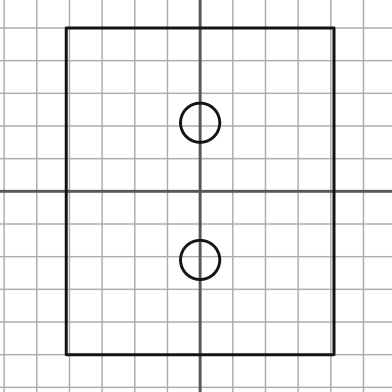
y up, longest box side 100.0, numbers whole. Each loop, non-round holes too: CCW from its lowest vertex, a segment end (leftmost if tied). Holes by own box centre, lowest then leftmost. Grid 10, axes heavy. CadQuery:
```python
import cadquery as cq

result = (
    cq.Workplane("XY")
    .moveTo(-41.0, -50.0)
    .lineTo(41.0, -50.0)
    .lineTo(41.0, 50.0)
    .lineTo(-41.0, 50.0)
    .close()
    .moveTo(0.0, -21.0)
    .circle(6.0)
    .moveTo(0.0, 21.0)
    .circle(6.0)
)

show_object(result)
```